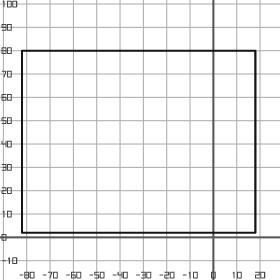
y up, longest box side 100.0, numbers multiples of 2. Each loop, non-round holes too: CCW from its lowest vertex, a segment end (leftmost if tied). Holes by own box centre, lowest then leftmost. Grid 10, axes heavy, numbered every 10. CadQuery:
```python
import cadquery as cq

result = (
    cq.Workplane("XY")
    .moveTo(-82.0, 2.0)
    .lineTo(18.0, 2.0)
    .lineTo(18.0, 80.0)
    .lineTo(-82.0, 80.0)
    .close()
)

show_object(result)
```